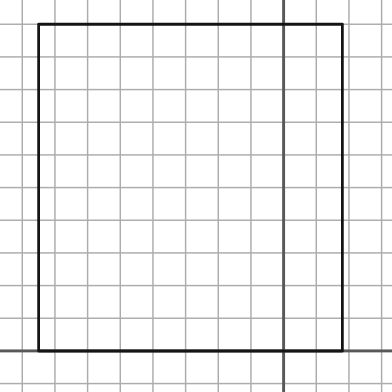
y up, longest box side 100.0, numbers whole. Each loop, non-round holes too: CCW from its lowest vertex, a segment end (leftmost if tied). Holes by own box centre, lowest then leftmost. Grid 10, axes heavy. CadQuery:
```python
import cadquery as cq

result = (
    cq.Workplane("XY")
    .moveTo(-75.0, 0.0)
    .lineTo(18.0, 0.0)
    .lineTo(18.0, 100.0)
    .lineTo(-75.0, 100.0)
    .close()
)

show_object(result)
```